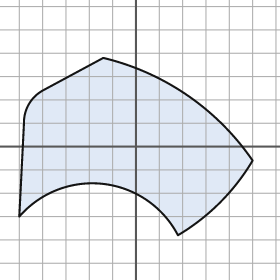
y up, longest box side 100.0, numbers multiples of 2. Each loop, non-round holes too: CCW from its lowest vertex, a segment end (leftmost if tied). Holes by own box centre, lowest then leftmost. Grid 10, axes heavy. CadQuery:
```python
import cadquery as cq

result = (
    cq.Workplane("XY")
    .moveTo(18.0, -38.0)
    .threePointArc((36.0, -24.0), (50.0, -6.0))
    .threePointArc((22.0, 22.0), (-14.0, 38.0))
    .lineTo(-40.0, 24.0)
    .threePointArc((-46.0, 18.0), (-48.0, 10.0))
    .lineTo(-50.0, -30.0)
    .threePointArc((-14.0, -16.0), (18.0, -38.0))
    .close()
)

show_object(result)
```